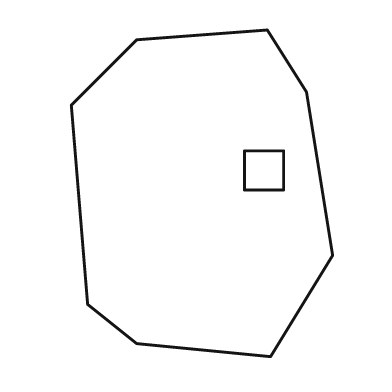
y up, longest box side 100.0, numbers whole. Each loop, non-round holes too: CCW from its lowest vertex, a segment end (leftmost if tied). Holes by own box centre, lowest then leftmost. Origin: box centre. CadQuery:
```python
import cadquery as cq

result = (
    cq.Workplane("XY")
    .moveTo(21.0, -50.0)
    .lineTo(40.0, -19.0)
    .lineTo(32.0, 31.0)
    .lineTo(20.0, 50.0)
    .lineTo(-20.0, 47.0)
    .lineTo(-40.0, 27.0)
    .lineTo(-35.0, -34.0)
    .lineTo(-20.0, -46.0)
    .close()
    .moveTo(13.0, 1.0)
    .lineTo(25.0, 1.0)
    .lineTo(25.0, 13.0)
    .lineTo(13.0, 13.0)
    .close()
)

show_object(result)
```